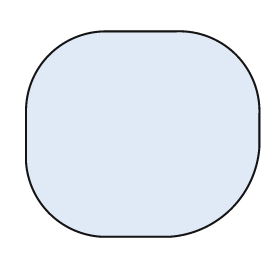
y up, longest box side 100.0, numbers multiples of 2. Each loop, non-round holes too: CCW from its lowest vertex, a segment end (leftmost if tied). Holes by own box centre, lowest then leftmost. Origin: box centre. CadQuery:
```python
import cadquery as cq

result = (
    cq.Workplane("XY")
    .moveTo(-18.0, -44.0)
    .lineTo(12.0, -44.0)
    .threePointArc((38.0, -32.0), (50.0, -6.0))
    .lineTo(50.0, 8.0)
    .threePointArc((40.0, 34.0), (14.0, 44.0))
    .lineTo(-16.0, 44.0)
    .threePointArc((-40.0, 34.0), (-50.0, 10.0))
    .lineTo(-50.0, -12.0)
    .threePointArc((-40.0, -34.0), (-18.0, -44.0))
    .close()
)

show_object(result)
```